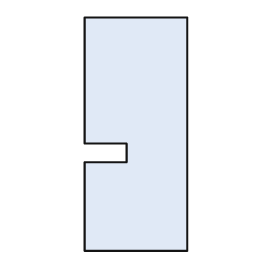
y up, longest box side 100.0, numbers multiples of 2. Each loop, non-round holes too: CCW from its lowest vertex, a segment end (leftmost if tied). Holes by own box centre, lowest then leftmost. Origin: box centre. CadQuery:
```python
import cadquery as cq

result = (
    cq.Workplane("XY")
    .moveTo(-22.0, -50.0)
    .lineTo(22.0, -50.0)
    .lineTo(22.0, 50.0)
    .lineTo(-22.0, 50.0)
    .lineTo(-22.0, -4.0)
    .lineTo(-4.0, -4.0)
    .lineTo(-4.0, -12.0)
    .lineTo(-22.0, -12.0)
    .close()
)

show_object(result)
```